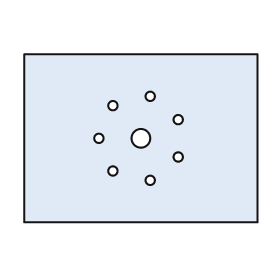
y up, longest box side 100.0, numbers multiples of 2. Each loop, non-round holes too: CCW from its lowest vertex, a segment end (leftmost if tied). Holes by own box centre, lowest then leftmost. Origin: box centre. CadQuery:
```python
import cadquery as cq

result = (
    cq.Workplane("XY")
    .moveTo(-50.0, -36.0)
    .lineTo(50.0, -36.0)
    .lineTo(50.0, 36.0)
    .lineTo(-50.0, 36.0)
    .close()
    .moveTo(4.0, -18.0)
    .circle(2.0)
    .moveTo(-12.0, -14.0)
    .circle(2.0)
    .moveTo(16.0, -8.0)
    .circle(2.0)
    .moveTo(-18.0, 0.0)
    .circle(2.0)
    .moveTo(0.0, 0.0)
    .circle(4.0)
    .moveTo(16.0, 8.0)
    .circle(2.0)
    .moveTo(-12.0, 14.0)
    .circle(2.0)
    .moveTo(4.0, 18.0)
    .circle(2.0)
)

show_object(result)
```